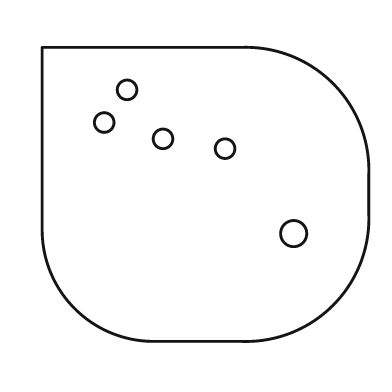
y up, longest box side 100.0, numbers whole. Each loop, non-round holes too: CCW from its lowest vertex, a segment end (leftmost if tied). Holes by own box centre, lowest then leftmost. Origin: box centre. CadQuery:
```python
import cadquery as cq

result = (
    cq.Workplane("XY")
    .moveTo(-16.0, -45.0)
    .lineTo(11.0, -45.0)
    .threePointArc((39.0, -34.0), (50.0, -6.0))
    .lineTo(50.0, 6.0)
    .threePointArc((39.0, 34.0), (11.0, 45.0))
    .lineTo(-50.0, 45.0)
    .lineTo(-50.0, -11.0)
    .threePointArc((-40.0, -35.0), (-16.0, -45.0))
    .close()
    .moveTo(27.0, -12.0)
    .circle(4.0)
    .moveTo(6.0, 14.0)
    .circle(3.0)
    .moveTo(-13.0, 17.0)
    .circle(3.0)
    .moveTo(-31.0, 22.0)
    .circle(3.0)
    .moveTo(-24.0, 32.0)
    .circle(3.0)
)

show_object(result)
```